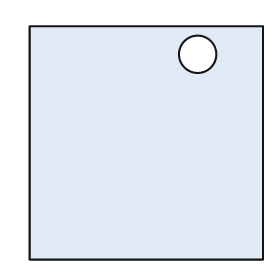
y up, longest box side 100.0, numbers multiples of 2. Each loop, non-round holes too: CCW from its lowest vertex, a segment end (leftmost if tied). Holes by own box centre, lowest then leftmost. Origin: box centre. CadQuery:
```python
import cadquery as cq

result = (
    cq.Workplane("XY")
    .moveTo(-50.0, -50.0)
    .lineTo(50.0, -50.0)
    .lineTo(50.0, 50.0)
    .lineTo(-50.0, 50.0)
    .close()
    .moveTo(22.0, 38.0)
    .circle(8.0)
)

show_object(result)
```